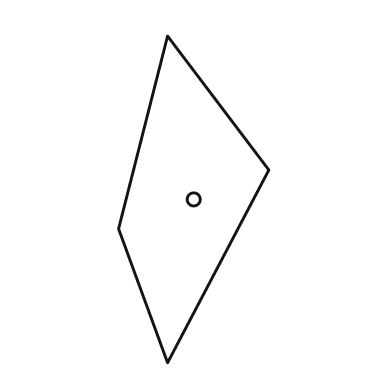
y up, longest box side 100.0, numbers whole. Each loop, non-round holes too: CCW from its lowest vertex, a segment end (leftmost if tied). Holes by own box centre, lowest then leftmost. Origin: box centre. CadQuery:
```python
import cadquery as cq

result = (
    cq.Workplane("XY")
    .moveTo(-8.0, -50.0)
    .lineTo(23.0, 9.0)
    .lineTo(-8.0, 50.0)
    .lineTo(-23.0, -9.0)
    .close()
    .moveTo(0.0, 0.0)
    .circle(2.0)
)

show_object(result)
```